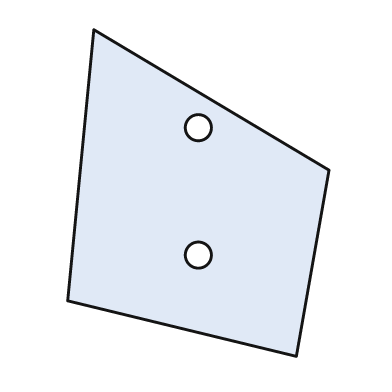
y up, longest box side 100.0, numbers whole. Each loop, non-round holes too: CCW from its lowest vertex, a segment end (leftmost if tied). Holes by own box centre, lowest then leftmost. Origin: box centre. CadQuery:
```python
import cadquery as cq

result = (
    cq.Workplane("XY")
    .moveTo(30.0, -50.0)
    .lineTo(40.0, 7.0)
    .lineTo(-32.0, 50.0)
    .lineTo(-40.0, -33.0)
    .close()
    .moveTo(0.0, -19.0)
    .circle(4.0)
    .moveTo(0.0, 20.0)
    .circle(4.0)
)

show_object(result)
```